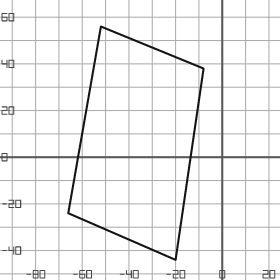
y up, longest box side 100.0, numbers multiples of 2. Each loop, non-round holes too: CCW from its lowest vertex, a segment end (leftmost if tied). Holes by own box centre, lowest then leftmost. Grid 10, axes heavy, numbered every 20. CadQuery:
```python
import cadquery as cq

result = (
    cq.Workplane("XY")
    .moveTo(-20.0, -44.0)
    .lineTo(-8.0, 38.0)
    .lineTo(-52.0, 56.0)
    .lineTo(-66.0, -24.0)
    .close()
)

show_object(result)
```